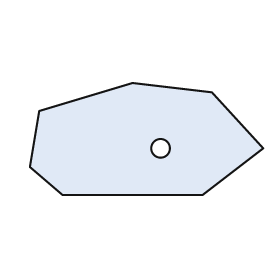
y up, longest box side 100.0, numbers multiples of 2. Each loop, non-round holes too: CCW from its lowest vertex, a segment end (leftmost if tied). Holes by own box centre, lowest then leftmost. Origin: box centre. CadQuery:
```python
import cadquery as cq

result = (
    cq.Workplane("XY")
    .moveTo(-36.0, -24.0)
    .lineTo(24.0, -24.0)
    .lineTo(50.0, -4.0)
    .lineTo(28.0, 20.0)
    .lineTo(-6.0, 24.0)
    .lineTo(-46.0, 12.0)
    .lineTo(-50.0, -12.0)
    .close()
    .moveTo(6.0, -4.0)
    .circle(4.0)
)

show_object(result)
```